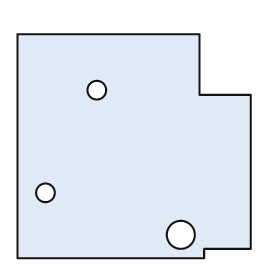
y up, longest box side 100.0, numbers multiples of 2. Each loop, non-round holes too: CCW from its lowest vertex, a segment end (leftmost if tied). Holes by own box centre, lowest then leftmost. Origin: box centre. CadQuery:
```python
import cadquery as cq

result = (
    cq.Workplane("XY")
    .moveTo(-50.0, -48.0)
    .lineTo(30.0, -48.0)
    .lineTo(30.0, -44.0)
    .lineTo(50.0, -44.0)
    .lineTo(50.0, 22.0)
    .lineTo(28.0, 22.0)
    .lineTo(28.0, 48.0)
    .lineTo(-50.0, 48.0)
    .close()
    .moveTo(20.0, -38.0)
    .circle(6.0)
    .moveTo(-38.0, -20.0)
    .circle(4.0)
    .moveTo(-16.0, 24.0)
    .circle(4.0)
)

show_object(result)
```